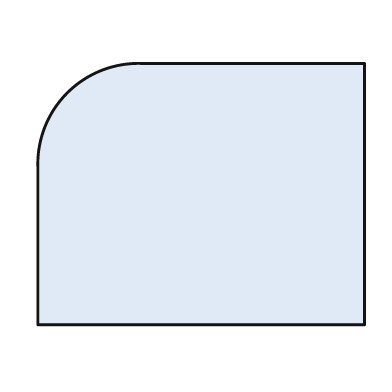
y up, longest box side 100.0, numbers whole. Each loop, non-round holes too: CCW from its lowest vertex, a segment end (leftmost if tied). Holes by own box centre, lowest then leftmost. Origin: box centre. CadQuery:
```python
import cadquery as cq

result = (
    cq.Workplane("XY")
    .moveTo(-50.0, -40.0)
    .lineTo(50.0, -40.0)
    .lineTo(50.0, 40.0)
    .lineTo(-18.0, 40.0)
    .threePointArc((-41.0, 31.0), (-50.0, 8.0))
    .close()
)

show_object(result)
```